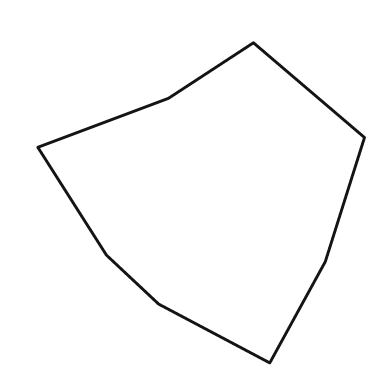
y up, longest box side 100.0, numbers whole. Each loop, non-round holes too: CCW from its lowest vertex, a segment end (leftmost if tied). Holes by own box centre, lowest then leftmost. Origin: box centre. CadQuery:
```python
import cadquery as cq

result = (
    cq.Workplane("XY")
    .moveTo(21.0, -49.0)
    .lineTo(38.0, -18.0)
    .lineTo(50.0, 20.0)
    .lineTo(16.0, 49.0)
    .lineTo(-10.0, 32.0)
    .lineTo(-50.0, 17.0)
    .lineTo(-29.0, -16.0)
    .lineTo(-13.0, -31.0)
    .close()
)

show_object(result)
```